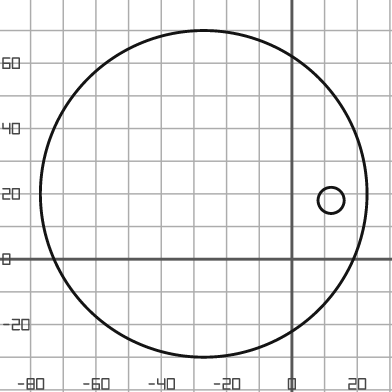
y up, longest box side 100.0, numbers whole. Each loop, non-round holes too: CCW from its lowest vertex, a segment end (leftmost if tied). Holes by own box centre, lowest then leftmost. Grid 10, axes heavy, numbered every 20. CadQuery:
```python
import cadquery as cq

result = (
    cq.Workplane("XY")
    .moveTo(-27.0, 20.0)
    .circle(50.0)
    .moveTo(12.0, 18.0)
    .circle(4.0)
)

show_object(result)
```